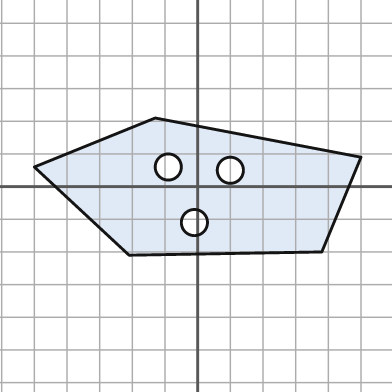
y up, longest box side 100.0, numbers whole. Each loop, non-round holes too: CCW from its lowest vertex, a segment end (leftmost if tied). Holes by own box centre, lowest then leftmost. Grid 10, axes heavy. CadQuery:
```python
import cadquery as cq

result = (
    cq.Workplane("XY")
    .moveTo(-21.0, -21.0)
    .lineTo(38.0, -20.0)
    .lineTo(50.0, 9.0)
    .lineTo(-13.0, 21.0)
    .lineTo(-50.0, 6.0)
    .close()
    .moveTo(-1.0, -11.0)
    .circle(4.0)
    .moveTo(10.0, 5.0)
    .circle(4.0)
    .moveTo(-9.0, 6.0)
    .circle(4.0)
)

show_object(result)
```